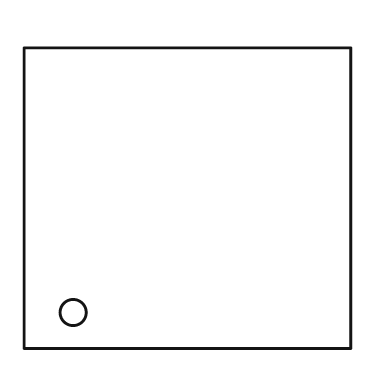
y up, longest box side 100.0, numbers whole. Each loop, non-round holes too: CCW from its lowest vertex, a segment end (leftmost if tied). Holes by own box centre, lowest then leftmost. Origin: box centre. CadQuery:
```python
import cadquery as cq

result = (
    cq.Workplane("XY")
    .moveTo(-50.0, -46.0)
    .lineTo(50.0, -46.0)
    .lineTo(50.0, 46.0)
    .lineTo(-50.0, 46.0)
    .close()
    .moveTo(-35.0, -35.0)
    .circle(4.0)
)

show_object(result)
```